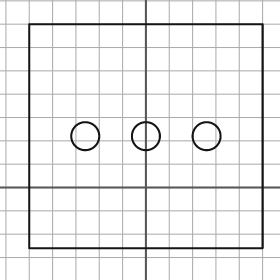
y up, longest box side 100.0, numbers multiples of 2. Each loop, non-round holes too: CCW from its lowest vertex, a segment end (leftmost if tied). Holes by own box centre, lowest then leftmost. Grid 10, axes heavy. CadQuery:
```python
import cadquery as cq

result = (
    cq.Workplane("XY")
    .moveTo(-50.0, -26.0)
    .lineTo(50.0, -26.0)
    .lineTo(50.0, 70.0)
    .lineTo(-50.0, 70.0)
    .close()
    .moveTo(-26.0, 22.0)
    .circle(6.0)
    .moveTo(0.0, 22.0)
    .circle(6.0)
    .moveTo(26.0, 22.0)
    .circle(6.0)
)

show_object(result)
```